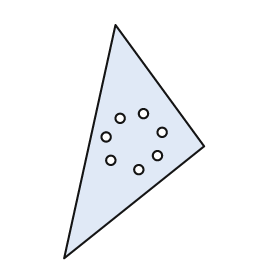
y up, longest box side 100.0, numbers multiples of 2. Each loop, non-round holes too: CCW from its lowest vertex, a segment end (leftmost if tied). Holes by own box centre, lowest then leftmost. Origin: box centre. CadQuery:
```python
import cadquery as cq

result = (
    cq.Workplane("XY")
    .moveTo(-30.0, -50.0)
    .lineTo(30.0, -2.0)
    .lineTo(-8.0, 50.0)
    .close()
    .moveTo(2.0, -12.0)
    .circle(2.0)
    .moveTo(-10.0, -8.0)
    .circle(2.0)
    .moveTo(10.0, -6.0)
    .circle(2.0)
    .moveTo(-12.0, 2.0)
    .circle(2.0)
    .moveTo(12.0, 4.0)
    .circle(2.0)
    .moveTo(-6.0, 10.0)
    .circle(2.0)
    .moveTo(4.0, 12.0)
    .circle(2.0)
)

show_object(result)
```